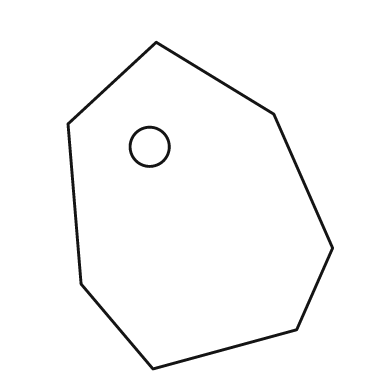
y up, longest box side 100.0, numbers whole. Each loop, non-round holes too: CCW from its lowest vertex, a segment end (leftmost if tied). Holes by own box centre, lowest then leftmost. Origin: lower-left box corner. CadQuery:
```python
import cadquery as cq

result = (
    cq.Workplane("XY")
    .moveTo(26.0, 0.0)
    .lineTo(70.0, 12.0)
    .lineTo(81.0, 37.0)
    .lineTo(63.0, 78.0)
    .lineTo(27.0, 100.0)
    .lineTo(0.0, 75.0)
    .lineTo(4.0, 26.0)
    .close()
    .moveTo(25.0, 68.0)
    .circle(6.0)
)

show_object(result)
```